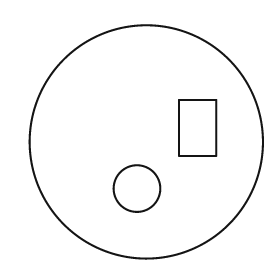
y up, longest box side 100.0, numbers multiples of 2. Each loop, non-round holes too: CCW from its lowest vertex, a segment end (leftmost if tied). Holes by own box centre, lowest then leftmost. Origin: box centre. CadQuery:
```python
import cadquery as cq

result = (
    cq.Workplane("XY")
    .moveTo(0.0, 0.0)
    .circle(50.0)
    .moveTo(-4.0, -20.0)
    .circle(10.0)
    .moveTo(14.0, -6.0)
    .lineTo(30.0, -6.0)
    .lineTo(30.0, 18.0)
    .lineTo(14.0, 18.0)
    .close()
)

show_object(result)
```